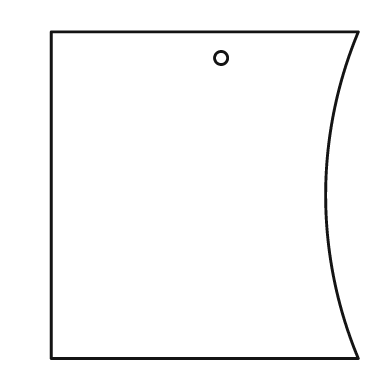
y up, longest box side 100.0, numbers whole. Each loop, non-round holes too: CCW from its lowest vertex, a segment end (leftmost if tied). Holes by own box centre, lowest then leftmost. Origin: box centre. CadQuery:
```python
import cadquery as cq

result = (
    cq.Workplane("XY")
    .moveTo(-47.0, -50.0)
    .lineTo(47.0, -50.0)
    .threePointArc((37.0, 0.0), (47.0, 50.0))
    .lineTo(-47.0, 50.0)
    .close()
    .moveTo(5.0, 42.0)
    .circle(2.0)
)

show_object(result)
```